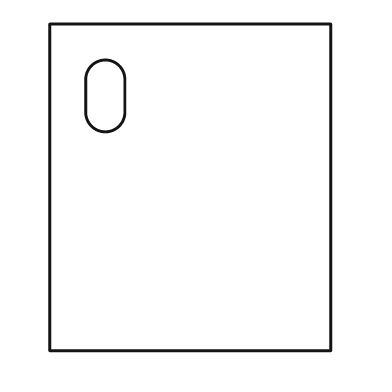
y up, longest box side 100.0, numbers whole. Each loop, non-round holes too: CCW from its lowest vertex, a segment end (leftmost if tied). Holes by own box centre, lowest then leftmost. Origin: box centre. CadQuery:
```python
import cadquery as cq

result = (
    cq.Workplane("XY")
    .moveTo(-43.0, -50.0)
    .lineTo(43.0, -50.0)
    .lineTo(43.0, 50.0)
    .lineTo(-43.0, 50.0)
    .close()
    .moveTo(-32.0, 23.0)
    .threePointArc((-26.0, 17.0), (-20.0, 23.0))
    .lineTo(-20.0, 33.0)
    .threePointArc((-26.0, 39.0), (-32.0, 33.0))
    .close()
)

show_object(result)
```